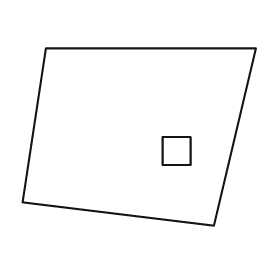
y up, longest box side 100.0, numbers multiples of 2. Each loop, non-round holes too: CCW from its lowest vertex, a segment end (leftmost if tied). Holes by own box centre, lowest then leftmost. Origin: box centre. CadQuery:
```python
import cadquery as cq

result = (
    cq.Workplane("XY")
    .moveTo(32.0, -38.0)
    .lineTo(50.0, 38.0)
    .lineTo(-40.0, 38.0)
    .lineTo(-50.0, -28.0)
    .close()
    .moveTo(10.0, -12.0)
    .lineTo(22.0, -12.0)
    .lineTo(22.0, 0.0)
    .lineTo(10.0, 0.0)
    .close()
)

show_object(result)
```